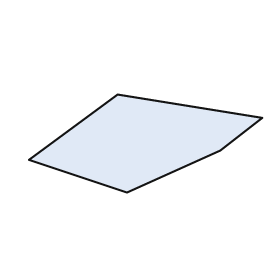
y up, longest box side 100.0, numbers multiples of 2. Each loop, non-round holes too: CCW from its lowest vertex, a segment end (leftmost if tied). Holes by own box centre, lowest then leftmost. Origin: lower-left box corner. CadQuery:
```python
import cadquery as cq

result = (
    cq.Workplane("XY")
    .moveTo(42.0, 0.0)
    .lineTo(82.0, 18.0)
    .lineTo(100.0, 32.0)
    .lineTo(38.0, 42.0)
    .lineTo(0.0, 14.0)
    .close()
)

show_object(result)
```